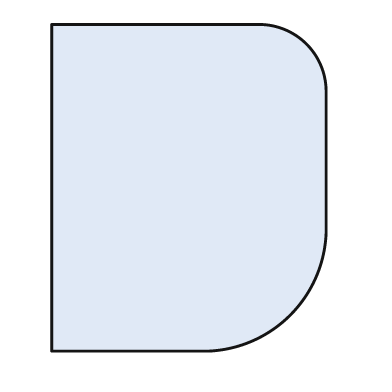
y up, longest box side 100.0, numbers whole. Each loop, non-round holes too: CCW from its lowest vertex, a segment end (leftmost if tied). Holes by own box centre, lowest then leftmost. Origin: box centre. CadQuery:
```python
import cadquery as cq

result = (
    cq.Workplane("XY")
    .moveTo(-42.0, -50.0)
    .lineTo(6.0, -50.0)
    .threePointArc((31.0, -39.0), (42.0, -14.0))
    .lineTo(42.0, 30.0)
    .threePointArc((36.0, 44.0), (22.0, 50.0))
    .lineTo(-42.0, 50.0)
    .close()
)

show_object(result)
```